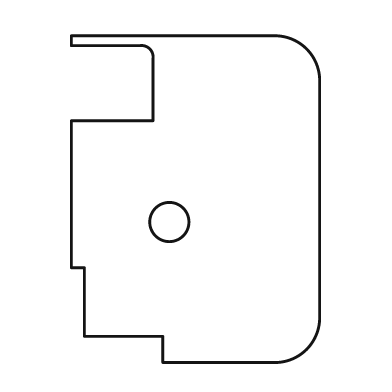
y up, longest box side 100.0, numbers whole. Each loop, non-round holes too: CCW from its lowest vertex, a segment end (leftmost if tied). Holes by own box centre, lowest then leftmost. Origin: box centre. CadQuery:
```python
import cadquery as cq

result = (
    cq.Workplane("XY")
    .moveTo(-10.0, -50.0)
    .lineTo(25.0, -50.0)
    .threePointArc((34.0, -46.0), (38.0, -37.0))
    .lineTo(38.0, 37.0)
    .threePointArc((34.0, 46.0), (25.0, 50.0))
    .lineTo(-38.0, 50.0)
    .lineTo(-38.0, 47.0)
    .lineTo(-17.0, 47.0)
    .threePointArc((-14.0, 46.0), (-13.0, 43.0))
    .lineTo(-13.0, 24.0)
    .lineTo(-38.0, 24.0)
    .lineTo(-38.0, -21.0)
    .lineTo(-34.0, -21.0)
    .lineTo(-34.0, -42.0)
    .lineTo(-10.0, -42.0)
    .close()
    .moveTo(-8.0, -7.0)
    .circle(6.0)
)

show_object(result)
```